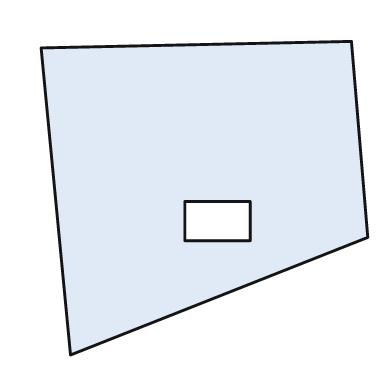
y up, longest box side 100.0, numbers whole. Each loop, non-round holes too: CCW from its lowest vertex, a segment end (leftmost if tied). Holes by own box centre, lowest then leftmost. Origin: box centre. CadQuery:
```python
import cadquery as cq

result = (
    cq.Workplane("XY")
    .moveTo(-41.0, -48.0)
    .lineTo(50.0, -12.0)
    .lineTo(45.0, 48.0)
    .lineTo(-50.0, 46.0)
    .close()
    .moveTo(-6.0, -13.0)
    .lineTo(14.0, -13.0)
    .lineTo(14.0, -1.0)
    .lineTo(-6.0, -1.0)
    .close()
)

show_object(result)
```